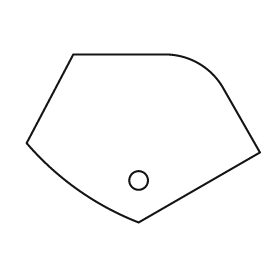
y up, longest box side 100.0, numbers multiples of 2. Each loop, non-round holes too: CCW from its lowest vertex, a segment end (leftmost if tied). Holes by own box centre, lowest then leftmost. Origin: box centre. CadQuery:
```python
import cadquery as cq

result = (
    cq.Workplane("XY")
    .moveTo(-2.0, -36.0)
    .lineTo(50.0, -6.0)
    .lineTo(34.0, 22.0)
    .threePointArc((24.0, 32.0), (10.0, 36.0))
    .lineTo(-30.0, 36.0)
    .lineTo(-50.0, -2.0)
    .threePointArc((-28.0, -22.0), (-2.0, -36.0))
    .close()
    .moveTo(-2.0, -18.0)
    .circle(4.0)
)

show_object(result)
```